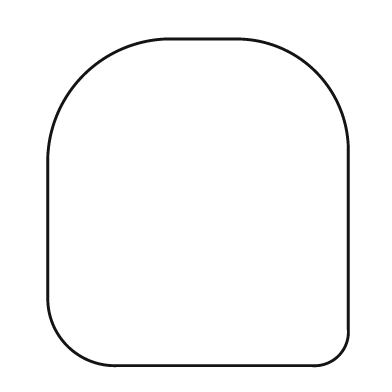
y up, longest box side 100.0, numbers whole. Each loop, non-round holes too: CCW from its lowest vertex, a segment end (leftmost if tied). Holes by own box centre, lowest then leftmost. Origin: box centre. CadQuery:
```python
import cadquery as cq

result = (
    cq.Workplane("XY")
    .moveTo(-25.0, -50.0)
    .lineTo(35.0, -50.0)
    .threePointArc((43.0, -47.0), (46.0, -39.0))
    .lineTo(46.0, 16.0)
    .threePointArc((36.0, 40.0), (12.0, 50.0))
    .lineTo(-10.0, 50.0)
    .threePointArc((-35.0, 39.0), (-46.0, 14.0))
    .lineTo(-46.0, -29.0)
    .threePointArc((-40.0, -44.0), (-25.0, -50.0))
    .close()
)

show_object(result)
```